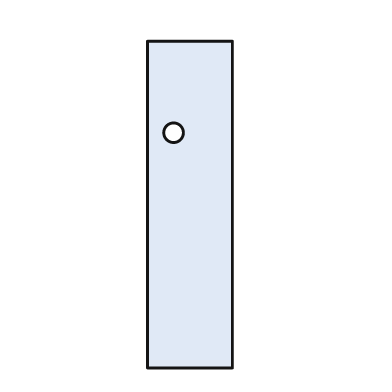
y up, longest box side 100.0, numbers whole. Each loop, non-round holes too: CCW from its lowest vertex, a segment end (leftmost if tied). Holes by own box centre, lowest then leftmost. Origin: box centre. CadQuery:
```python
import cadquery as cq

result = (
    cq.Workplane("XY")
    .moveTo(-13.0, -50.0)
    .lineTo(13.0, -50.0)
    .lineTo(13.0, 50.0)
    .lineTo(-13.0, 50.0)
    .close()
    .moveTo(-5.0, 22.0)
    .circle(3.0)
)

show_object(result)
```